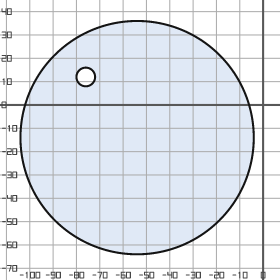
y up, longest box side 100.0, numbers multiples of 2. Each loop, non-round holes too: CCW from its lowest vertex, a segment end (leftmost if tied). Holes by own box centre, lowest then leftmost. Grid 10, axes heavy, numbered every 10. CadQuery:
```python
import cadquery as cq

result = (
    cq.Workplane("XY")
    .moveTo(-54.0, -14.0)
    .circle(50.0)
    .moveTo(-76.0, 12.0)
    .circle(4.0)
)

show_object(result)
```